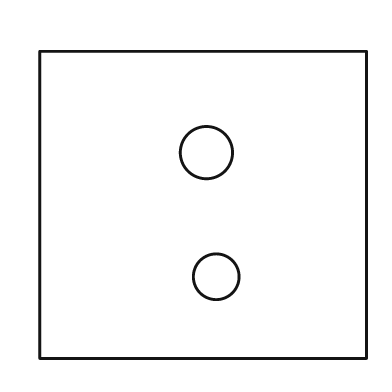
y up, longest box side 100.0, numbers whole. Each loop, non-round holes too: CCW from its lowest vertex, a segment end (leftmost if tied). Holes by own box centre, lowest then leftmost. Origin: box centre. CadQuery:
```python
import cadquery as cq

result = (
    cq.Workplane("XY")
    .moveTo(-50.0, -47.0)
    .lineTo(50.0, -47.0)
    .lineTo(50.0, 47.0)
    .lineTo(-50.0, 47.0)
    .close()
    .moveTo(4.0, -22.0)
    .circle(7.0)
    .moveTo(1.0, 16.0)
    .circle(8.0)
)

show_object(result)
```